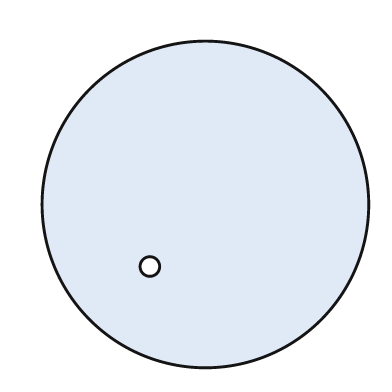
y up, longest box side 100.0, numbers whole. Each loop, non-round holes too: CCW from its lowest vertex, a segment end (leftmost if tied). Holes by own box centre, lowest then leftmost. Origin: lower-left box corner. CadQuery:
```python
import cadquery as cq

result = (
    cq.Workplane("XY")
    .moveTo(50.0, 50.0)
    .circle(50.0)
    .moveTo(33.0, 31.0)
    .circle(3.0)
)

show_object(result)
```